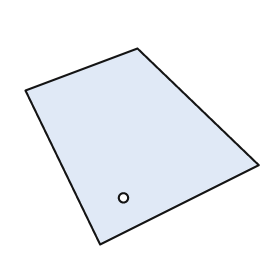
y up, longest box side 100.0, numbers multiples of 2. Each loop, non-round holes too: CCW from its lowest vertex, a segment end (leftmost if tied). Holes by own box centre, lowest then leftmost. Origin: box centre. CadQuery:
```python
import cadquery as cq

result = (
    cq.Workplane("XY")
    .moveTo(-18.0, -42.0)
    .lineTo(50.0, -8.0)
    .lineTo(-2.0, 42.0)
    .lineTo(-50.0, 24.0)
    .close()
    .moveTo(-8.0, -22.0)
    .circle(2.0)
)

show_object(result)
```